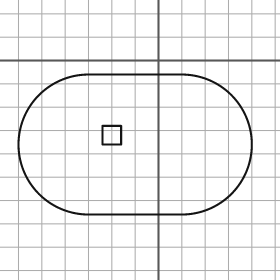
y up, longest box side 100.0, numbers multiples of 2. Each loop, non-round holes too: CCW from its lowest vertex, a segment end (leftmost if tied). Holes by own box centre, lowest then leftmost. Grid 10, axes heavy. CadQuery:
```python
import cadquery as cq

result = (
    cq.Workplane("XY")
    .moveTo(-30.0, -66.0)
    .lineTo(10.0, -66.0)
    .threePointArc((40.0, -36.0), (10.0, -6.0))
    .lineTo(-30.0, -6.0)
    .threePointArc((-60.0, -36.0), (-30.0, -66.0))
    .close()
    .moveTo(-24.0, -36.0)
    .lineTo(-16.0, -36.0)
    .lineTo(-16.0, -28.0)
    .lineTo(-24.0, -28.0)
    .close()
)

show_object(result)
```